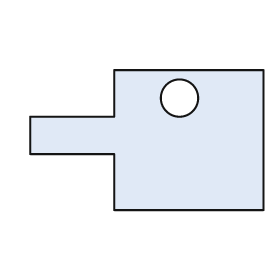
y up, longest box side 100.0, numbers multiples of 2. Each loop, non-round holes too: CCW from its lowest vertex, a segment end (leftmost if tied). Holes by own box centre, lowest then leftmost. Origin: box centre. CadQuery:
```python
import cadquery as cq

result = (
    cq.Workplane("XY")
    .moveTo(-14.0, -30.0)
    .lineTo(50.0, -30.0)
    .lineTo(50.0, 30.0)
    .lineTo(-14.0, 30.0)
    .lineTo(-14.0, 10.0)
    .lineTo(-50.0, 10.0)
    .lineTo(-50.0, -6.0)
    .lineTo(-14.0, -6.0)
    .close()
    .moveTo(14.0, 18.0)
    .circle(8.0)
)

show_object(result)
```